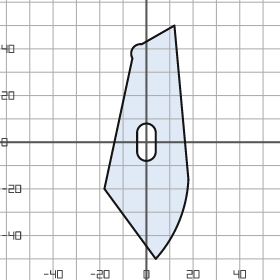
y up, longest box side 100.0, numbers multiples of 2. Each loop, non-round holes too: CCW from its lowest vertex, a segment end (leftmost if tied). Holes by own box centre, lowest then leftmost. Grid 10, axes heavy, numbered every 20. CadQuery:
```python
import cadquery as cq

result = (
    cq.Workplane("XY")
    .moveTo(4.0, -50.0)
    .threePointArc((14.0, -34.0), (18.0, -16.0))
    .lineTo(12.0, 50.0)
    .lineTo(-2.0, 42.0)
    .threePointArc((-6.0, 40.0), (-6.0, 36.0))
    .lineTo(-18.0, -20.0)
    .close()
    .moveTo(-4.0, -4.0)
    .threePointArc((0.0, -8.0), (4.0, -4.0))
    .lineTo(4.0, 4.0)
    .threePointArc((0.0, 8.0), (-4.0, 4.0))
    .close()
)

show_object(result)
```